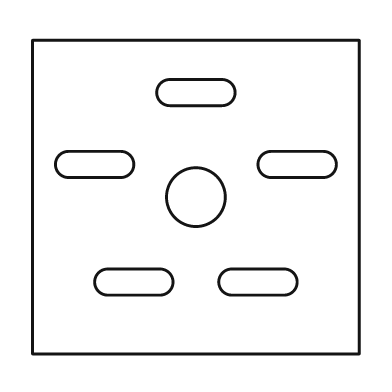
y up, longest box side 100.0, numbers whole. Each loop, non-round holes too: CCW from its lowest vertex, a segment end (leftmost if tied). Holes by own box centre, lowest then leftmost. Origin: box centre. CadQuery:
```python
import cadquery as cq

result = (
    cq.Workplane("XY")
    .moveTo(-50.0, -48.0)
    .lineTo(50.0, -48.0)
    .lineTo(50.0, 48.0)
    .lineTo(-50.0, 48.0)
    .close()
    .moveTo(-27.0, -30.0)
    .lineTo(-11.0, -30.0)
    .threePointArc((-7.0, -26.0), (-11.0, -22.0))
    .lineTo(-27.0, -22.0)
    .threePointArc((-31.0, -26.0), (-27.0, -30.0))
    .close()
    .moveTo(11.0, -30.0)
    .lineTo(27.0, -30.0)
    .threePointArc((31.0, -26.0), (27.0, -22.0))
    .lineTo(11.0, -22.0)
    .threePointArc((7.0, -26.0), (11.0, -30.0))
    .close()
    .moveTo(0.0, 0.0)
    .circle(9.0)
    .moveTo(-39.0, 6.0)
    .lineTo(-23.0, 6.0)
    .threePointArc((-19.0, 10.0), (-23.0, 14.0))
    .lineTo(-39.0, 14.0)
    .threePointArc((-43.0, 10.0), (-39.0, 6.0))
    .close()
    .moveTo(23.0, 6.0)
    .lineTo(39.0, 6.0)
    .threePointArc((43.0, 10.0), (39.0, 14.0))
    .lineTo(23.0, 14.0)
    .threePointArc((19.0, 10.0), (23.0, 6.0))
    .close()
    .moveTo(-8.0, 28.0)
    .lineTo(8.0, 28.0)
    .threePointArc((12.0, 32.0), (8.0, 36.0))
    .lineTo(-8.0, 36.0)
    .threePointArc((-12.0, 32.0), (-8.0, 28.0))
    .close()
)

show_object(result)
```